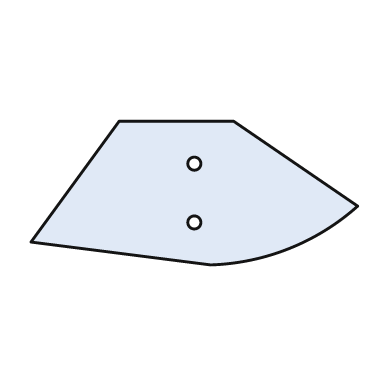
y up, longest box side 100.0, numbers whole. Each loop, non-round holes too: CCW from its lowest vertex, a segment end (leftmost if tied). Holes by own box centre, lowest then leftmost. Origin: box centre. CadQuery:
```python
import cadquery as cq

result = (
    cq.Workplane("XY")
    .moveTo(5.0, -22.0)
    .threePointArc((29.0, -17.0), (50.0, -4.0))
    .lineTo(12.0, 22.0)
    .lineTo(-23.0, 22.0)
    .lineTo(-50.0, -15.0)
    .close()
    .moveTo(0.0, -9.0)
    .circle(2.0)
    .moveTo(0.0, 9.0)
    .circle(2.0)
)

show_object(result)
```